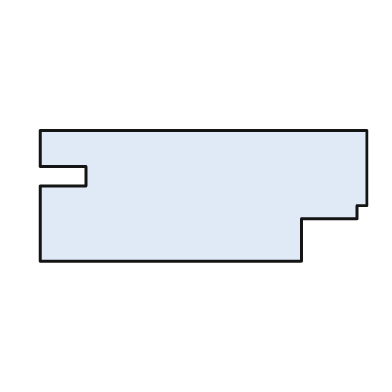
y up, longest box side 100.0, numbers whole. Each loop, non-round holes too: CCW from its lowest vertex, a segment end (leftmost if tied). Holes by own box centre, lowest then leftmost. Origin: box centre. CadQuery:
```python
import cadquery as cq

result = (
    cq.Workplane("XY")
    .moveTo(-50.0, -20.0)
    .lineTo(30.0, -20.0)
    .lineTo(30.0, -7.0)
    .lineTo(47.0, -7.0)
    .lineTo(47.0, -3.0)
    .lineTo(50.0, -3.0)
    .lineTo(50.0, 20.0)
    .lineTo(-50.0, 20.0)
    .lineTo(-50.0, 9.0)
    .lineTo(-36.0, 9.0)
    .lineTo(-36.0, 3.0)
    .lineTo(-50.0, 3.0)
    .close()
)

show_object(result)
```